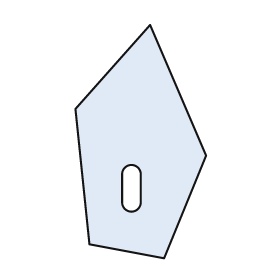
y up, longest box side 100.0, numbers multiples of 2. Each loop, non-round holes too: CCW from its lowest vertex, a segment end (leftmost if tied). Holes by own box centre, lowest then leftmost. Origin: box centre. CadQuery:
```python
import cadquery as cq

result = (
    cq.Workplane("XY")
    .moveTo(10.0, -50.0)
    .lineTo(28.0, -6.0)
    .lineTo(4.0, 50.0)
    .lineTo(-28.0, 14.0)
    .lineTo(-22.0, -44.0)
    .close()
    .moveTo(-8.0, -26.0)
    .threePointArc((-4.0, -30.0), (0.0, -26.0))
    .lineTo(0.0, -14.0)
    .threePointArc((-4.0, -10.0), (-8.0, -14.0))
    .close()
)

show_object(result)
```